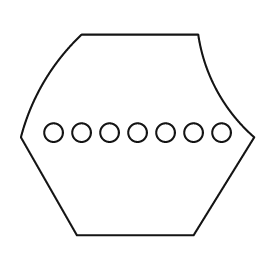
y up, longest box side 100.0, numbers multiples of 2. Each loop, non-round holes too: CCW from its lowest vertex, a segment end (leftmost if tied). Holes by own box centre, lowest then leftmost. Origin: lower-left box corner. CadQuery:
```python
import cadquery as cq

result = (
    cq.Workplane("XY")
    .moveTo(24.0, 0.0)
    .lineTo(74.0, 0.0)
    .lineTo(100.0, 42.0)
    .threePointArc((84.0, 62.0), (76.0, 86.0))
    .lineTo(26.0, 86.0)
    .threePointArc((10.0, 66.0), (0.0, 42.0))
    .close()
    .moveTo(14.0, 44.0)
    .circle(4.0)
    .moveTo(26.0, 44.0)
    .circle(4.0)
    .moveTo(38.0, 44.0)
    .circle(4.0)
    .moveTo(50.0, 44.0)
    .circle(4.0)
    .moveTo(62.0, 44.0)
    .circle(4.0)
    .moveTo(74.0, 44.0)
    .circle(4.0)
    .moveTo(86.0, 44.0)
    .circle(4.0)
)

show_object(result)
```